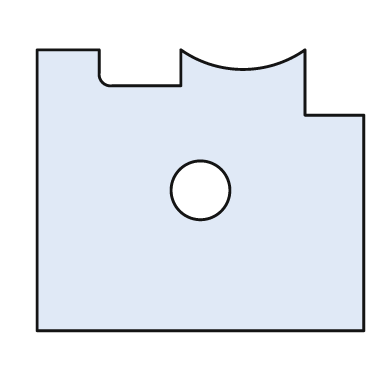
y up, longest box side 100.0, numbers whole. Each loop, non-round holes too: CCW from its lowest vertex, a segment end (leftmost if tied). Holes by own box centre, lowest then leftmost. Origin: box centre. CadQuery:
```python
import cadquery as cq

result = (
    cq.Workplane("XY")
    .moveTo(-50.0, -43.0)
    .lineTo(50.0, -43.0)
    .lineTo(50.0, 23.0)
    .lineTo(32.0, 23.0)
    .lineTo(32.0, 43.0)
    .threePointArc((13.0, 37.0), (-6.0, 43.0))
    .lineTo(-6.0, 32.0)
    .lineTo(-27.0, 32.0)
    .threePointArc((-30.0, 33.0), (-31.0, 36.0))
    .lineTo(-31.0, 43.0)
    .lineTo(-50.0, 43.0)
    .close()
    .moveTo(0.0, 0.0)
    .circle(9.0)
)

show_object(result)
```